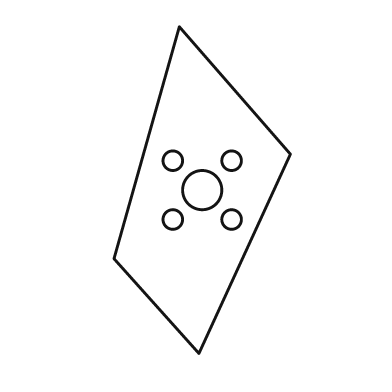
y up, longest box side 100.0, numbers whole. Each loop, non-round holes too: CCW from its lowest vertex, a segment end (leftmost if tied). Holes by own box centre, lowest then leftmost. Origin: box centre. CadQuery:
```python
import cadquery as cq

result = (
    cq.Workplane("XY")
    .moveTo(-1.0, -50.0)
    .lineTo(27.0, 11.0)
    .lineTo(-7.0, 50.0)
    .lineTo(-27.0, -21.0)
    .close()
    .moveTo(-9.0, -9.0)
    .circle(3.0)
    .moveTo(9.0, -9.0)
    .circle(3.0)
    .moveTo(0.0, 0.0)
    .circle(6.0)
    .moveTo(-9.0, 9.0)
    .circle(3.0)
    .moveTo(9.0, 9.0)
    .circle(3.0)
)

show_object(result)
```